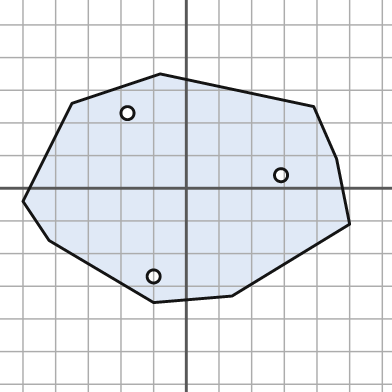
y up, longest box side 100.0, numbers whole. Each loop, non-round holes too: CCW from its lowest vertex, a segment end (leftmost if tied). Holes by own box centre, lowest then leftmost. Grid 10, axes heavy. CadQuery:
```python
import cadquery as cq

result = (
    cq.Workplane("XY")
    .moveTo(-10.0, -35.0)
    .lineTo(14.0, -33.0)
    .lineTo(50.0, -11.0)
    .lineTo(46.0, 9.0)
    .lineTo(39.0, 25.0)
    .lineTo(-8.0, 35.0)
    .lineTo(-35.0, 26.0)
    .lineTo(-50.0, -4.0)
    .lineTo(-42.0, -16.0)
    .close()
    .moveTo(-10.0, -27.0)
    .circle(2.0)
    .moveTo(29.0, 4.0)
    .circle(2.0)
    .moveTo(-18.0, 23.0)
    .circle(2.0)
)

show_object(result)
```